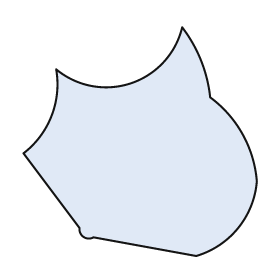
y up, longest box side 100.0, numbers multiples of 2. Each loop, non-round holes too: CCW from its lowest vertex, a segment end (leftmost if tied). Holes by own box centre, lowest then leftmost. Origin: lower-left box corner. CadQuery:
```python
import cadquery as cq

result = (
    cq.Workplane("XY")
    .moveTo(74.0, 0.0)
    .threePointArc((92.0, 12.0), (100.0, 32.0))
    .threePointArc((94.0, 52.0), (80.0, 68.0))
    .threePointArc((76.0, 84.0), (68.0, 98.0))
    .threePointArc((46.0, 74.0), (14.0, 80.0))
    .threePointArc((12.0, 60.0), (0.0, 44.0))
    .lineTo(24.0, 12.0)
    .threePointArc((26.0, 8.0), (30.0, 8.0))
    .close()
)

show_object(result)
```